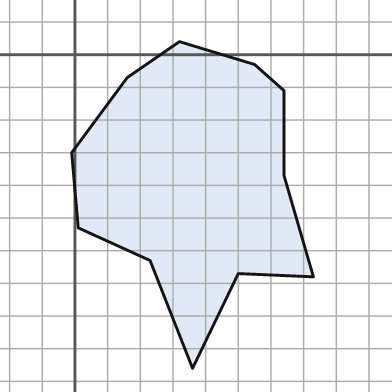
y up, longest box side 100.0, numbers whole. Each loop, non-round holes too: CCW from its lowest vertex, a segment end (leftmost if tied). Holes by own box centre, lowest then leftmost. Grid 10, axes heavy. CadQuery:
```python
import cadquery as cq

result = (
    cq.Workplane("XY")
    .moveTo(36.0, -96.0)
    .lineTo(50.0, -67.0)
    .lineTo(73.0, -68.0)
    .lineTo(64.0, -37.0)
    .lineTo(64.0, -11.0)
    .lineTo(55.0, -3.0)
    .lineTo(32.0, 4.0)
    .lineTo(16.0, -7.0)
    .lineTo(-1.0, -30.0)
    .lineTo(1.0, -53.0)
    .lineTo(23.0, -63.0)
    .close()
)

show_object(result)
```